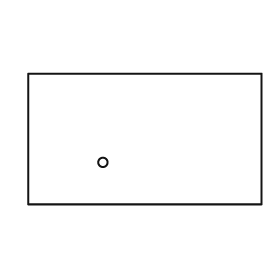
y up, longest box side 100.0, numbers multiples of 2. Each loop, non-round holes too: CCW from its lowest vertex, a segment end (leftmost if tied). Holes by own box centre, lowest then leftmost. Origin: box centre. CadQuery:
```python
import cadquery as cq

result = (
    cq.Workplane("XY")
    .moveTo(-50.0, -28.0)
    .lineTo(50.0, -28.0)
    .lineTo(50.0, 28.0)
    .lineTo(-50.0, 28.0)
    .close()
    .moveTo(-18.0, -10.0)
    .circle(2.0)
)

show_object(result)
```